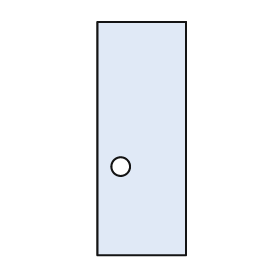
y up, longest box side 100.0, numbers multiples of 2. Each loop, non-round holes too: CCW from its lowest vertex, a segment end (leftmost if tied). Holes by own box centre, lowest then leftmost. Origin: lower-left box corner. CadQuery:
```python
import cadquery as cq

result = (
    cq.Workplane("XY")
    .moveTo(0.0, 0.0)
    .lineTo(38.0, 0.0)
    .lineTo(38.0, 100.0)
    .lineTo(0.0, 100.0)
    .close()
    .moveTo(10.0, 38.0)
    .circle(4.0)
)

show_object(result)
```